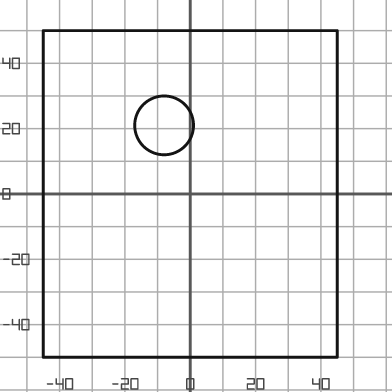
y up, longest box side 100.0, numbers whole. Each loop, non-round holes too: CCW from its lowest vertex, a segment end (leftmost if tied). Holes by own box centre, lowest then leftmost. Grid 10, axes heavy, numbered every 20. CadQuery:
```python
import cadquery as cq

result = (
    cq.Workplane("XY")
    .moveTo(-45.0, -50.0)
    .lineTo(45.0, -50.0)
    .lineTo(45.0, 50.0)
    .lineTo(-45.0, 50.0)
    .close()
    .moveTo(-8.0, 21.0)
    .circle(9.0)
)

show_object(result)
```